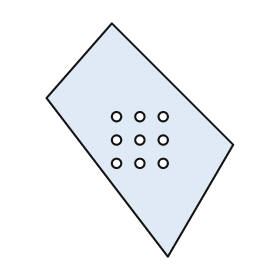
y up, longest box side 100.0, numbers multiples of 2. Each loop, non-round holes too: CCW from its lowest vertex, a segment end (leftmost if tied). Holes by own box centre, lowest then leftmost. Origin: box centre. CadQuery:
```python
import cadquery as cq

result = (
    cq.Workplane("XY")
    .moveTo(12.0, -50.0)
    .lineTo(40.0, -2.0)
    .lineTo(-12.0, 50.0)
    .lineTo(-40.0, 18.0)
    .close()
    .moveTo(-10.0, -10.0)
    .circle(2.0)
    .moveTo(0.0, -10.0)
    .circle(2.0)
    .moveTo(10.0, -10.0)
    .circle(2.0)
    .moveTo(-10.0, 0.0)
    .circle(2.0)
    .moveTo(0.0, 0.0)
    .circle(2.0)
    .moveTo(10.0, 0.0)
    .circle(2.0)
    .moveTo(-10.0, 10.0)
    .circle(2.0)
    .moveTo(0.0, 10.0)
    .circle(2.0)
    .moveTo(10.0, 10.0)
    .circle(2.0)
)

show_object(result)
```